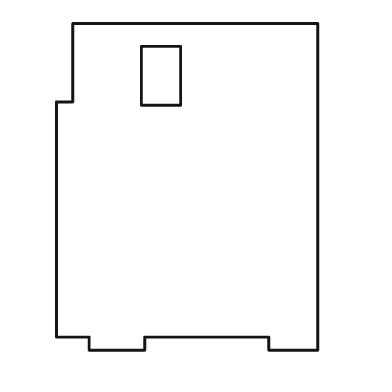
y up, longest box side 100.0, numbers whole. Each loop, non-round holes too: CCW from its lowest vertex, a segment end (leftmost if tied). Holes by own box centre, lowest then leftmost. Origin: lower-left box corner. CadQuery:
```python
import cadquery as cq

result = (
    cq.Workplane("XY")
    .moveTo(10.0, 0.0)
    .lineTo(27.0, 0.0)
    .lineTo(27.0, 4.0)
    .lineTo(65.0, 4.0)
    .lineTo(65.0, 0.0)
    .lineTo(80.0, 0.0)
    .lineTo(80.0, 100.0)
    .lineTo(5.0, 100.0)
    .lineTo(5.0, 76.0)
    .lineTo(0.0, 76.0)
    .lineTo(0.0, 4.0)
    .lineTo(10.0, 4.0)
    .close()
    .moveTo(26.0, 75.0)
    .lineTo(38.0, 75.0)
    .lineTo(38.0, 93.0)
    .lineTo(26.0, 93.0)
    .close()
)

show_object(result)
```